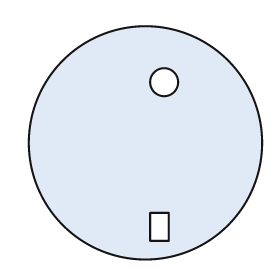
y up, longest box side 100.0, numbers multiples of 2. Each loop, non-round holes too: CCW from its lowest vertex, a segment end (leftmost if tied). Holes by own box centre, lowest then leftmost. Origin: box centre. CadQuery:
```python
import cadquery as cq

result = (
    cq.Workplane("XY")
    .moveTo(0.0, 0.0)
    .circle(50.0)
    .moveTo(2.0, -42.0)
    .lineTo(10.0, -42.0)
    .lineTo(10.0, -30.0)
    .lineTo(2.0, -30.0)
    .close()
    .moveTo(8.0, 26.0)
    .circle(6.0)
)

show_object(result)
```